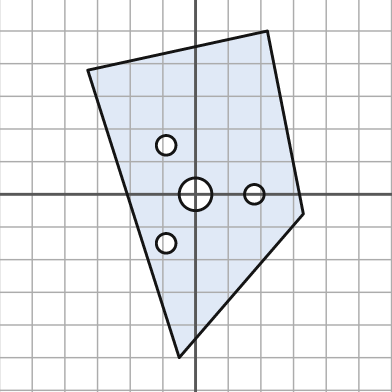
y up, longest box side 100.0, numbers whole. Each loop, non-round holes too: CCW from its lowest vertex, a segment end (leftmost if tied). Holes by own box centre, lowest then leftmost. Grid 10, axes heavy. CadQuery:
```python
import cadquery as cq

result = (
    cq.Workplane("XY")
    .moveTo(-5.0, -50.0)
    .lineTo(33.0, -6.0)
    .lineTo(22.0, 50.0)
    .lineTo(-33.0, 38.0)
    .close()
    .moveTo(-9.0, -15.0)
    .circle(3.0)
    .moveTo(0.0, 0.0)
    .circle(5.0)
    .moveTo(18.0, 0.0)
    .circle(3.0)
    .moveTo(-9.0, 15.0)
    .circle(3.0)
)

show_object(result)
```